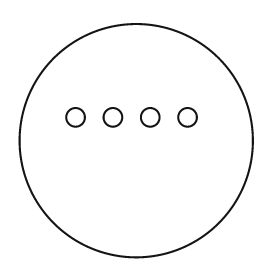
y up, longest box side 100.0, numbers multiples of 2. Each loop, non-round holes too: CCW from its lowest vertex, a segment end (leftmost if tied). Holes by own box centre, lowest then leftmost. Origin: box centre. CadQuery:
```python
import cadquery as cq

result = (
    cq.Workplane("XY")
    .moveTo(0.0, 0.0)
    .circle(50.0)
    .moveTo(-26.0, 10.0)
    .circle(4.0)
    .moveTo(-10.0, 10.0)
    .circle(4.0)
    .moveTo(6.0, 10.0)
    .circle(4.0)
    .moveTo(22.0, 10.0)
    .circle(4.0)
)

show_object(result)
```